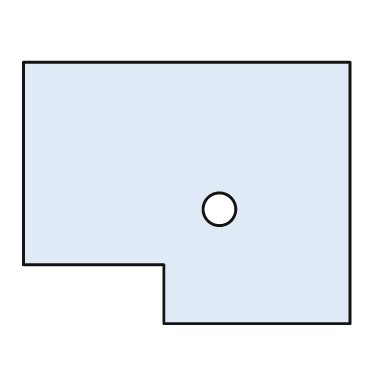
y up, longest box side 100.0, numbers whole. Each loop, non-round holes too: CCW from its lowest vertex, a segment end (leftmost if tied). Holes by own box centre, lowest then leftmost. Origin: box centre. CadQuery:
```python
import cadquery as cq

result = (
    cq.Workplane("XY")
    .moveTo(-7.0, -40.0)
    .lineTo(50.0, -40.0)
    .lineTo(50.0, 40.0)
    .lineTo(-50.0, 40.0)
    .lineTo(-50.0, -22.0)
    .lineTo(-7.0, -22.0)
    .close()
    .moveTo(10.0, -5.0)
    .circle(5.0)
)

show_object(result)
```